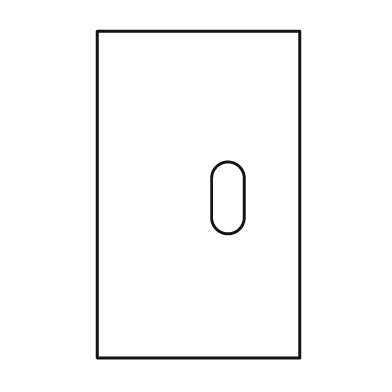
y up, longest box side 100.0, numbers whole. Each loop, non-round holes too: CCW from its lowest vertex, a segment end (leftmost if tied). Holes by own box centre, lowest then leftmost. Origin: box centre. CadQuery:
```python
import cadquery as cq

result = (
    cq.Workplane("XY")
    .moveTo(-31.0, -50.0)
    .lineTo(31.0, -50.0)
    .lineTo(31.0, 50.0)
    .lineTo(-31.0, 50.0)
    .close()
    .moveTo(4.0, -7.0)
    .threePointArc((9.0, -12.0), (14.0, -7.0))
    .lineTo(14.0, 5.0)
    .threePointArc((9.0, 10.0), (4.0, 5.0))
    .close()
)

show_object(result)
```